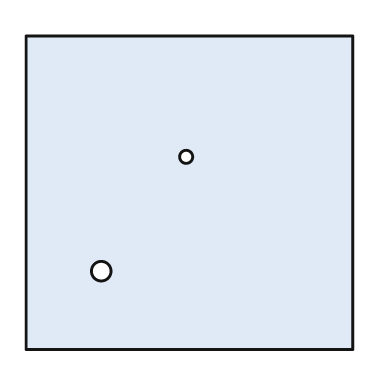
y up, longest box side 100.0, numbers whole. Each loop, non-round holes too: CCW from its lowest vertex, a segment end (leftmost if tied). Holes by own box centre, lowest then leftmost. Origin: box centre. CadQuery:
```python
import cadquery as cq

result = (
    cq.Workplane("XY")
    .moveTo(-50.0, -48.0)
    .lineTo(50.0, -48.0)
    .lineTo(50.0, 48.0)
    .lineTo(-50.0, 48.0)
    .close()
    .moveTo(-27.0, -24.0)
    .circle(3.0)
    .moveTo(-1.0, 11.0)
    .circle(2.0)
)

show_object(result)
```